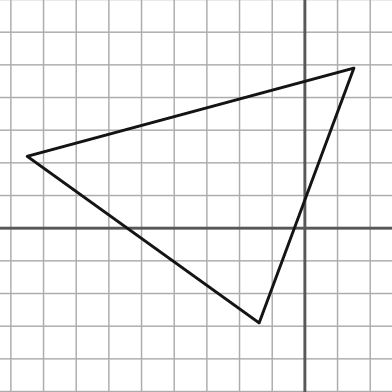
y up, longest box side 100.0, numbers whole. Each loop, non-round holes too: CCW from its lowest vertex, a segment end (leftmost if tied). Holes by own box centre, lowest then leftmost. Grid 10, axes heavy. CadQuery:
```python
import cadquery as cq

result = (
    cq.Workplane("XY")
    .moveTo(-14.0, -29.0)
    .lineTo(15.0, 49.0)
    .lineTo(-85.0, 22.0)
    .close()
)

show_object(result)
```